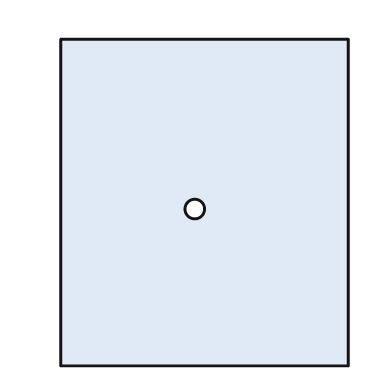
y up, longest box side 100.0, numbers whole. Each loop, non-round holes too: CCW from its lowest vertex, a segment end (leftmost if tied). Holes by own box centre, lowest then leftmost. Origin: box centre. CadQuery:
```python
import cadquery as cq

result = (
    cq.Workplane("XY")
    .moveTo(-44.0, -50.0)
    .lineTo(44.0, -50.0)
    .lineTo(44.0, 50.0)
    .lineTo(-44.0, 50.0)
    .close()
    .moveTo(-3.0, -2.0)
    .circle(3.0)
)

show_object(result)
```